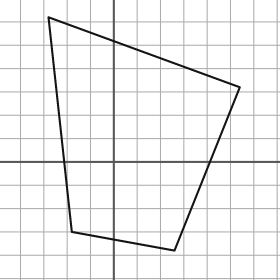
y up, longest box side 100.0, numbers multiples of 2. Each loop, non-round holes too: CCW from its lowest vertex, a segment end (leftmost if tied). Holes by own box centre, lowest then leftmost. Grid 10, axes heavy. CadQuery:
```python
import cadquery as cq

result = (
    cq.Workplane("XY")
    .moveTo(26.0, -38.0)
    .lineTo(54.0, 32.0)
    .lineTo(-28.0, 62.0)
    .lineTo(-18.0, -30.0)
    .close()
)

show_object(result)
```